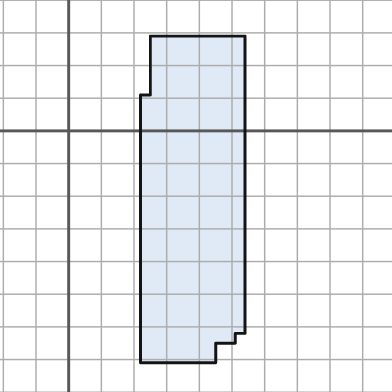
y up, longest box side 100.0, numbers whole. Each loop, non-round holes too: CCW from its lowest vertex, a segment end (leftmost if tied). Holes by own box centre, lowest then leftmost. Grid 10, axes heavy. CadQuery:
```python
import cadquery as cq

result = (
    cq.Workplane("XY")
    .moveTo(22.0, -71.0)
    .lineTo(45.0, -71.0)
    .lineTo(45.0, -65.0)
    .lineTo(51.0, -65.0)
    .lineTo(51.0, -62.0)
    .lineTo(54.0, -62.0)
    .lineTo(54.0, 29.0)
    .lineTo(25.0, 29.0)
    .lineTo(25.0, 11.0)
    .lineTo(22.0, 11.0)
    .close()
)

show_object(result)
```